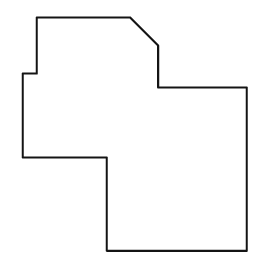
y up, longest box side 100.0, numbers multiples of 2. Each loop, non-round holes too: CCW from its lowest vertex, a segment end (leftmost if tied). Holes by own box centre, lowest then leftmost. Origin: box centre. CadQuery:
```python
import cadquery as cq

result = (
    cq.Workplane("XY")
    .moveTo(-12.0, -50.0)
    .lineTo(48.0, -50.0)
    .lineTo(48.0, 20.0)
    .lineTo(10.0, 20.0)
    .lineTo(10.0, 38.0)
    .lineTo(-2.0, 50.0)
    .lineTo(-42.0, 50.0)
    .lineTo(-42.0, 26.0)
    .lineTo(-48.0, 26.0)
    .lineTo(-48.0, -10.0)
    .lineTo(-12.0, -10.0)
    .close()
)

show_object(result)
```